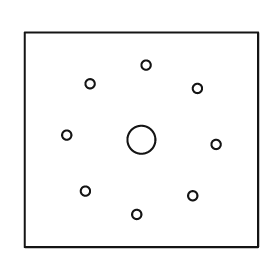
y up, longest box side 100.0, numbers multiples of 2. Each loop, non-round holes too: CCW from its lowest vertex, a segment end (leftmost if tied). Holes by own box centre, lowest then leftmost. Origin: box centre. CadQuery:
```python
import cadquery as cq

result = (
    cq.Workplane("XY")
    .moveTo(-50.0, -46.0)
    .lineTo(50.0, -46.0)
    .lineTo(50.0, 46.0)
    .lineTo(-50.0, 46.0)
    .close()
    .moveTo(-2.0, -32.0)
    .circle(2.0)
    .moveTo(22.0, -24.0)
    .circle(2.0)
    .moveTo(-24.0, -22.0)
    .circle(2.0)
    .moveTo(32.0, -2.0)
    .circle(2.0)
    .moveTo(0.0, 0.0)
    .circle(6.0)
    .moveTo(-32.0, 2.0)
    .circle(2.0)
    .moveTo(24.0, 22.0)
    .circle(2.0)
    .moveTo(-22.0, 24.0)
    .circle(2.0)
    .moveTo(2.0, 32.0)
    .circle(2.0)
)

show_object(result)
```